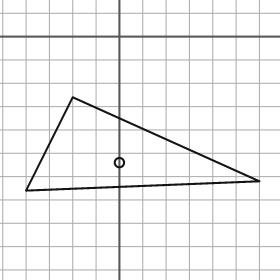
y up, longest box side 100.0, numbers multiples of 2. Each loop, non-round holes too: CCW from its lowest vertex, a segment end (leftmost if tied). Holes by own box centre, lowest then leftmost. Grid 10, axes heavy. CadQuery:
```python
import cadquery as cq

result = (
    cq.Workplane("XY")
    .moveTo(-40.0, -66.0)
    .lineTo(60.0, -62.0)
    .lineTo(-20.0, -26.0)
    .close()
    .moveTo(0.0, -54.0)
    .circle(2.0)
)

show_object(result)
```